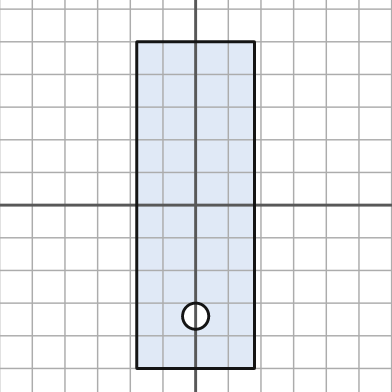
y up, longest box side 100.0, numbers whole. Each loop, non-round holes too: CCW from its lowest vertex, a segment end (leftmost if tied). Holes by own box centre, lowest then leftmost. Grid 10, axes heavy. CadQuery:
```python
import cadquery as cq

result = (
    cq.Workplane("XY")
    .moveTo(-18.0, -50.0)
    .lineTo(18.0, -50.0)
    .lineTo(18.0, 50.0)
    .lineTo(-18.0, 50.0)
    .close()
    .moveTo(0.0, -34.0)
    .circle(4.0)
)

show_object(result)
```